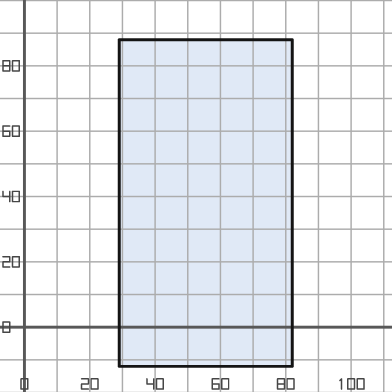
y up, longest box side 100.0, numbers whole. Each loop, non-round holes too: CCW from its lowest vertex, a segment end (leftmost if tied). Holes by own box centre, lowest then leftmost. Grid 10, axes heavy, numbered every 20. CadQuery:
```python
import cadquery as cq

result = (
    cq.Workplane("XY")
    .moveTo(29.0, -12.0)
    .lineTo(82.0, -12.0)
    .lineTo(82.0, 88.0)
    .lineTo(29.0, 88.0)
    .close()
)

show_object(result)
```